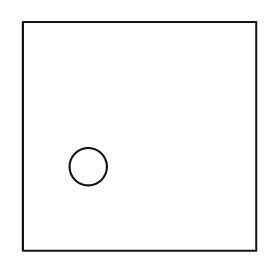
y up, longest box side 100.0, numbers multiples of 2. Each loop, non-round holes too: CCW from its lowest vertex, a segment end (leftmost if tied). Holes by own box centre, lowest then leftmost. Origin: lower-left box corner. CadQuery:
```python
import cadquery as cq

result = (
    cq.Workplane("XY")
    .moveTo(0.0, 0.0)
    .lineTo(100.0, 0.0)
    .lineTo(100.0, 98.0)
    .lineTo(0.0, 98.0)
    .close()
    .moveTo(28.0, 36.0)
    .circle(8.0)
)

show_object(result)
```